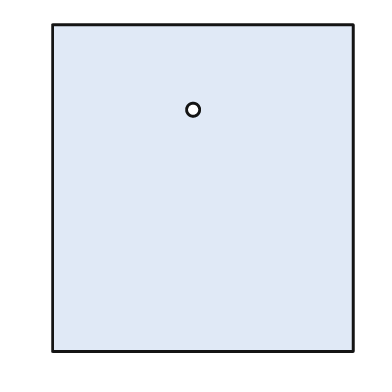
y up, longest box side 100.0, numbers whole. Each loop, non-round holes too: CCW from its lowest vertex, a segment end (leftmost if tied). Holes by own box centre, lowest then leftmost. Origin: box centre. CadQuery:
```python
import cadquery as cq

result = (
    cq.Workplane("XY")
    .moveTo(-46.0, -50.0)
    .lineTo(46.0, -50.0)
    .lineTo(46.0, 50.0)
    .lineTo(-46.0, 50.0)
    .close()
    .moveTo(-3.0, 24.0)
    .circle(2.0)
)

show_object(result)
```